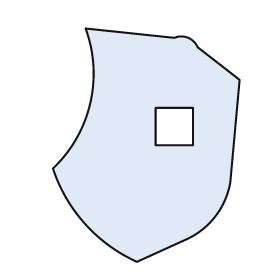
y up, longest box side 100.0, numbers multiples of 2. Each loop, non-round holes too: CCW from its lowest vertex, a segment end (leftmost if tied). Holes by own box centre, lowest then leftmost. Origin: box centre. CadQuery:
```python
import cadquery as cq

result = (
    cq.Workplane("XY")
    .moveTo(-4.0, -50.0)
    .lineTo(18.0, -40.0)
    .threePointArc((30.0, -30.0), (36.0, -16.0))
    .lineTo(40.0, 28.0)
    .lineTo(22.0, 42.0)
    .threePointArc((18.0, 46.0), (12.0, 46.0))
    .lineTo(-26.0, 50.0)
    .threePointArc((-24.0, 18.0), (-40.0, -10.0))
    .threePointArc((-26.0, -34.0), (-4.0, -50.0))
    .close()
    .moveTo(4.0, 0.0)
    .lineTo(20.0, 0.0)
    .lineTo(20.0, 16.0)
    .lineTo(4.0, 16.0)
    .close()
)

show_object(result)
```